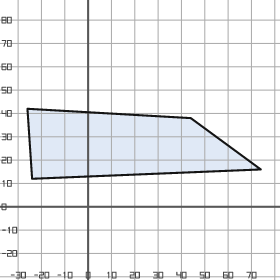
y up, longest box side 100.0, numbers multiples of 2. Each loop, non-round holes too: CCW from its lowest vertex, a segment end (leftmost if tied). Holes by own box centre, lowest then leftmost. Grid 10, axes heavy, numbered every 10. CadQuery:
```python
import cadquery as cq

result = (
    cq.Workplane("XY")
    .moveTo(-24.0, 12.0)
    .lineTo(74.0, 16.0)
    .lineTo(44.0, 38.0)
    .lineTo(-26.0, 42.0)
    .close()
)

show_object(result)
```